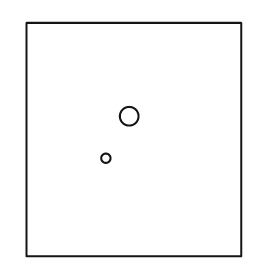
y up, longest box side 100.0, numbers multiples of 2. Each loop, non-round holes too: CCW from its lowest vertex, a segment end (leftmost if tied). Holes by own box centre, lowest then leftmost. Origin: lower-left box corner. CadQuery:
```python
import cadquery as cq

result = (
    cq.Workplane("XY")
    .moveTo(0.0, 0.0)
    .lineTo(92.0, 0.0)
    .lineTo(92.0, 100.0)
    .lineTo(0.0, 100.0)
    .close()
    .moveTo(34.0, 42.0)
    .circle(2.0)
    .moveTo(44.0, 60.0)
    .circle(4.0)
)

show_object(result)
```